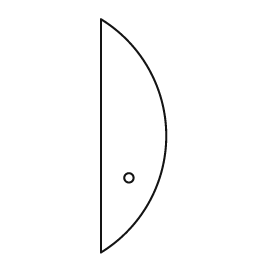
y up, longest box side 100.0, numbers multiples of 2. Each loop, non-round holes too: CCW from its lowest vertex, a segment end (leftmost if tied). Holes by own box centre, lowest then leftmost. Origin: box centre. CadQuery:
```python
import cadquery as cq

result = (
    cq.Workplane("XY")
    .moveTo(-14.0, -50.0)
    .threePointArc((14.0, 0.0), (-14.0, 50.0))
    .close()
    .moveTo(-2.0, -18.0)
    .circle(2.0)
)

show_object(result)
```